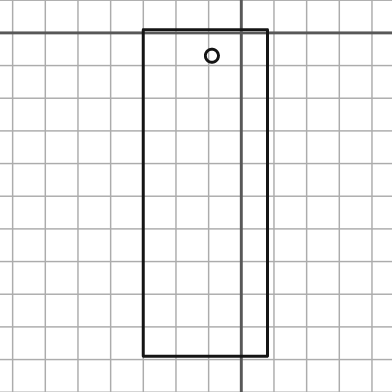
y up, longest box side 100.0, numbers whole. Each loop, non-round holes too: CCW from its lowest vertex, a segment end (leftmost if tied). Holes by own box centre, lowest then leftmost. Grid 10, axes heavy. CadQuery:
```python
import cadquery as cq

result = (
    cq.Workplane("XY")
    .moveTo(-30.0, -99.0)
    .lineTo(8.0, -99.0)
    .lineTo(8.0, 1.0)
    .lineTo(-30.0, 1.0)
    .close()
    .moveTo(-9.0, -7.0)
    .circle(2.0)
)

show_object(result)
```